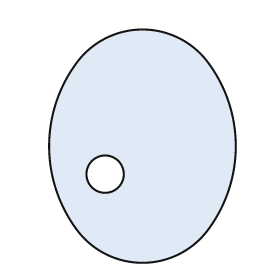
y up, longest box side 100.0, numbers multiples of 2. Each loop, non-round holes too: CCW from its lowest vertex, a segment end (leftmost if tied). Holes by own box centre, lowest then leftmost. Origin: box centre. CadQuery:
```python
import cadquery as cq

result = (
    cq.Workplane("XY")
    .moveTo(-28.0, -36.0)
    .threePointArc((0.0, -50.0), (28.0, -36.0))
    .threePointArc((40.0, 0.0), (28.0, 36.0))
    .threePointArc((0.0, 50.0), (-28.0, 36.0))
    .threePointArc((-40.0, 0.0), (-28.0, -36.0))
    .close()
    .moveTo(-16.0, -12.0)
    .circle(8.0)
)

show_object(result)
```